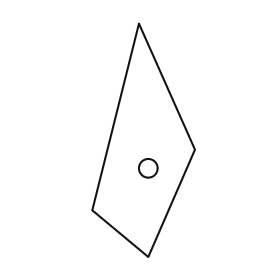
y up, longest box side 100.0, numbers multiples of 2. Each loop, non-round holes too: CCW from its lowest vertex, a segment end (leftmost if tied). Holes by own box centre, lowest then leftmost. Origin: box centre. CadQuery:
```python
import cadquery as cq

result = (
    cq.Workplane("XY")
    .moveTo(2.0, -50.0)
    .lineTo(22.0, -4.0)
    .lineTo(-2.0, 50.0)
    .lineTo(-22.0, -30.0)
    .close()
    .moveTo(2.0, -12.0)
    .circle(4.0)
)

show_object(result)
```